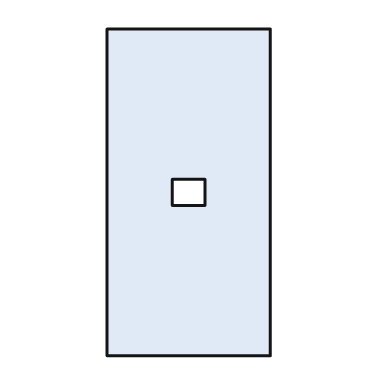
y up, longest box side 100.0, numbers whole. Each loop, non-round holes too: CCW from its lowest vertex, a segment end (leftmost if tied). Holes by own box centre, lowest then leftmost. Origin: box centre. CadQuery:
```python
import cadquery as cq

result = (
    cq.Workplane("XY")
    .moveTo(-25.0, -50.0)
    .lineTo(25.0, -50.0)
    .lineTo(25.0, 50.0)
    .lineTo(-25.0, 50.0)
    .close()
    .moveTo(-5.0, -4.0)
    .lineTo(5.0, -4.0)
    .lineTo(5.0, 4.0)
    .lineTo(-5.0, 4.0)
    .close()
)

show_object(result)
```